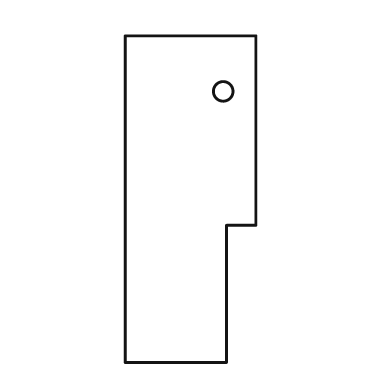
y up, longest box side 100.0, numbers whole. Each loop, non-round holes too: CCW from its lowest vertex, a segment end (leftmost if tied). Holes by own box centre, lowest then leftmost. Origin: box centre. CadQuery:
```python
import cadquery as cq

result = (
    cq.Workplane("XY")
    .moveTo(-20.0, -50.0)
    .lineTo(11.0, -50.0)
    .lineTo(11.0, -8.0)
    .lineTo(20.0, -8.0)
    .lineTo(20.0, 50.0)
    .lineTo(-20.0, 50.0)
    .close()
    .moveTo(10.0, 33.0)
    .circle(3.0)
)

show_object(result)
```